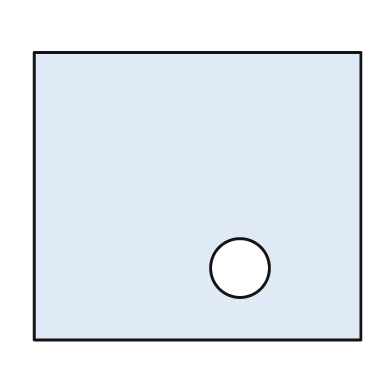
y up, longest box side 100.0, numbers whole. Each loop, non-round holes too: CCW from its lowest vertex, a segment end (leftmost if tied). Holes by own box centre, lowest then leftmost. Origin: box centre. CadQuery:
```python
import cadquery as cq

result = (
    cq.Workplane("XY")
    .moveTo(-50.0, -44.0)
    .lineTo(50.0, -44.0)
    .lineTo(50.0, 44.0)
    .lineTo(-50.0, 44.0)
    .close()
    .moveTo(13.0, -22.0)
    .circle(9.0)
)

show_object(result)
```